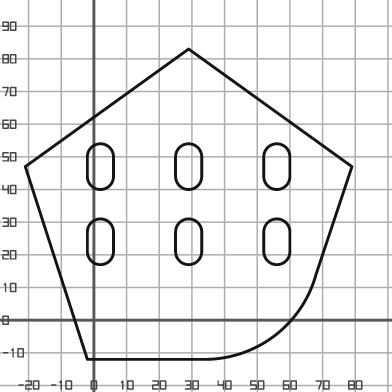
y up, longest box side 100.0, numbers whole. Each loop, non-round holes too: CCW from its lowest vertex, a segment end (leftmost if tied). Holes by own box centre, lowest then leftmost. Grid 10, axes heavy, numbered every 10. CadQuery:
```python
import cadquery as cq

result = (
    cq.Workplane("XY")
    .moveTo(-2.0, -12.0)
    .lineTo(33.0, -12.0)
    .threePointArc((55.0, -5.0), (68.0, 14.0))
    .lineTo(79.0, 47.0)
    .lineTo(29.0, 83.0)
    .lineTo(-21.0, 47.0)
    .close()
    .moveTo(-2.0, 21.0)
    .threePointArc((2.0, 17.0), (6.0, 21.0))
    .lineTo(6.0, 27.0)
    .threePointArc((2.0, 31.0), (-2.0, 27.0))
    .close()
    .moveTo(25.0, 21.0)
    .threePointArc((29.0, 17.0), (33.0, 21.0))
    .lineTo(33.0, 27.0)
    .threePointArc((29.0, 31.0), (25.0, 27.0))
    .close()
    .moveTo(52.0, 21.0)
    .threePointArc((56.0, 17.0), (60.0, 21.0))
    .lineTo(60.0, 27.0)
    .threePointArc((56.0, 31.0), (52.0, 27.0))
    .close()
    .moveTo(-2.0, 44.0)
    .threePointArc((2.0, 40.0), (6.0, 44.0))
    .lineTo(6.0, 50.0)
    .threePointArc((2.0, 54.0), (-2.0, 50.0))
    .close()
    .moveTo(25.0, 44.0)
    .threePointArc((29.0, 40.0), (33.0, 44.0))
    .lineTo(33.0, 50.0)
    .threePointArc((29.0, 54.0), (25.0, 50.0))
    .close()
    .moveTo(52.0, 44.0)
    .threePointArc((56.0, 40.0), (60.0, 44.0))
    .lineTo(60.0, 50.0)
    .threePointArc((56.0, 54.0), (52.0, 50.0))
    .close()
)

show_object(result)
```